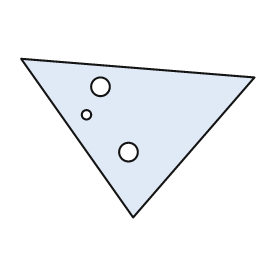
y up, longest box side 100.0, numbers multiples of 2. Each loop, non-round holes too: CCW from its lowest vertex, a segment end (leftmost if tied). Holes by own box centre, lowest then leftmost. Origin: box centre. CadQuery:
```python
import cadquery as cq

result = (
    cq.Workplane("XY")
    .moveTo(-2.0, -34.0)
    .lineTo(50.0, 26.0)
    .lineTo(-50.0, 34.0)
    .close()
    .moveTo(-4.0, -6.0)
    .circle(4.0)
    .moveTo(-22.0, 10.0)
    .circle(2.0)
    .moveTo(-16.0, 22.0)
    .circle(4.0)
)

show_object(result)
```